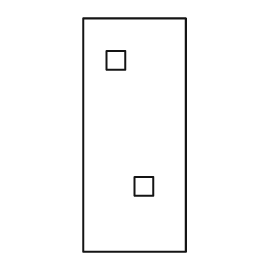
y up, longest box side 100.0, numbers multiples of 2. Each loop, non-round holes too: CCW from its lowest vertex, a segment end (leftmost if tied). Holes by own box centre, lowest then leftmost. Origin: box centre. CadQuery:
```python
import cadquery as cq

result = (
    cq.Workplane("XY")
    .moveTo(-22.0, -50.0)
    .lineTo(22.0, -50.0)
    .lineTo(22.0, 50.0)
    .lineTo(-22.0, 50.0)
    .close()
    .moveTo(0.0, -26.0)
    .lineTo(8.0, -26.0)
    .lineTo(8.0, -18.0)
    .lineTo(0.0, -18.0)
    .close()
    .moveTo(-12.0, 28.0)
    .lineTo(-4.0, 28.0)
    .lineTo(-4.0, 36.0)
    .lineTo(-12.0, 36.0)
    .close()
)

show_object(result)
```